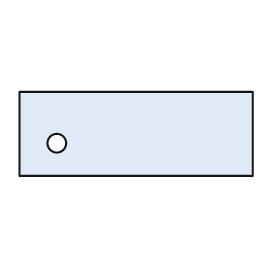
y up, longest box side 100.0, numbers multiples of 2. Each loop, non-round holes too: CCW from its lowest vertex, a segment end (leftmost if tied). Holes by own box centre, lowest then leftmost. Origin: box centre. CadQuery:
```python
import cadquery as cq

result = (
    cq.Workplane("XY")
    .moveTo(-50.0, -18.0)
    .lineTo(50.0, -18.0)
    .lineTo(50.0, 18.0)
    .lineTo(-50.0, 18.0)
    .close()
    .moveTo(-34.0, -4.0)
    .circle(4.0)
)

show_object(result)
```